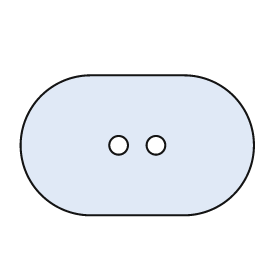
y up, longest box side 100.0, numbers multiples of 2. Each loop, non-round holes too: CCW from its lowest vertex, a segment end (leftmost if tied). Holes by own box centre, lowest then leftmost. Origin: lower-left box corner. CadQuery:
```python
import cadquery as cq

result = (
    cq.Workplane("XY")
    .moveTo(30.0, 0.0)
    .lineTo(70.0, 0.0)
    .threePointArc((100.0, 30.0), (70.0, 60.0))
    .lineTo(30.0, 60.0)
    .threePointArc((0.0, 30.0), (30.0, 0.0))
    .close()
    .moveTo(42.0, 30.0)
    .circle(4.0)
    .moveTo(58.0, 30.0)
    .circle(4.0)
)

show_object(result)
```